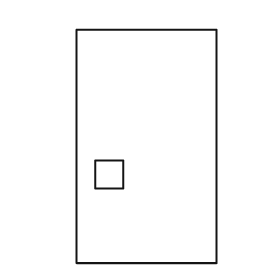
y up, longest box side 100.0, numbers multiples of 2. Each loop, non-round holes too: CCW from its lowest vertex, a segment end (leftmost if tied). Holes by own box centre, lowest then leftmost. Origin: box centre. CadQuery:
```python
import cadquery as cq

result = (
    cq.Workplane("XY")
    .moveTo(-30.0, -50.0)
    .lineTo(30.0, -50.0)
    .lineTo(30.0, 50.0)
    .lineTo(-30.0, 50.0)
    .close()
    .moveTo(-22.0, -18.0)
    .lineTo(-10.0, -18.0)
    .lineTo(-10.0, -6.0)
    .lineTo(-22.0, -6.0)
    .close()
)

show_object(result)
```